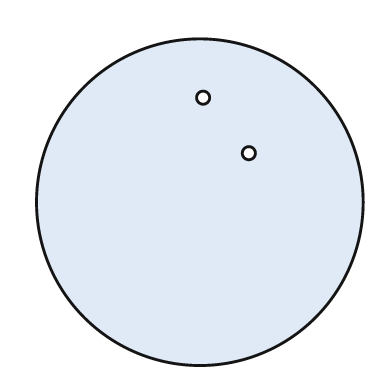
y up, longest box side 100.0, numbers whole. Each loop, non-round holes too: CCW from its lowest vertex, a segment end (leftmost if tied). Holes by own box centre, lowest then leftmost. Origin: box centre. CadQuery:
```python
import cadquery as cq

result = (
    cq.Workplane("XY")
    .moveTo(0.0, 0.0)
    .circle(50.0)
    .moveTo(15.0, 15.0)
    .circle(2.0)
    .moveTo(1.0, 32.0)
    .circle(2.0)
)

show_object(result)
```